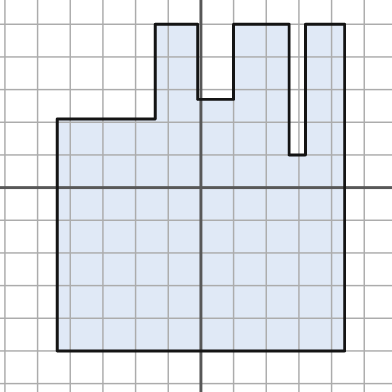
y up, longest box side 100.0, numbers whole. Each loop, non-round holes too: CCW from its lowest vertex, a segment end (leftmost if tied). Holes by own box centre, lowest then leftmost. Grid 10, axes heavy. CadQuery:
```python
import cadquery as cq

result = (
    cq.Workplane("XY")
    .moveTo(-44.0, -50.0)
    .lineTo(44.0, -50.0)
    .lineTo(44.0, 50.0)
    .lineTo(32.0, 50.0)
    .lineTo(32.0, 10.0)
    .lineTo(27.0, 10.0)
    .lineTo(27.0, 50.0)
    .lineTo(10.0, 50.0)
    .lineTo(10.0, 27.0)
    .lineTo(-1.0, 27.0)
    .lineTo(-1.0, 50.0)
    .lineTo(-14.0, 50.0)
    .lineTo(-14.0, 21.0)
    .lineTo(-44.0, 21.0)
    .close()
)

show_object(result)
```